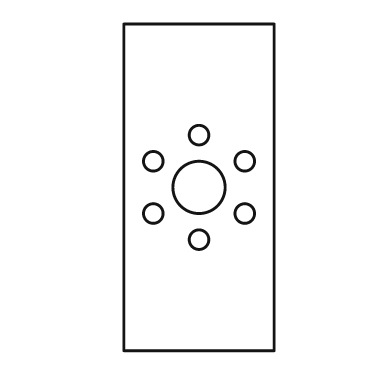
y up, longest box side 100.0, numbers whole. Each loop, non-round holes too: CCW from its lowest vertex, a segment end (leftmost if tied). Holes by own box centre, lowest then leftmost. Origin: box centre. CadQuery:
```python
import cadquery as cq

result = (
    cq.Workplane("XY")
    .moveTo(-23.0, -50.0)
    .lineTo(23.0, -50.0)
    .lineTo(23.0, 50.0)
    .lineTo(-23.0, 50.0)
    .close()
    .moveTo(0.0, -16.0)
    .circle(3.0)
    .moveTo(-14.0, -8.0)
    .circle(3.0)
    .moveTo(14.0, -8.0)
    .circle(3.0)
    .moveTo(0.0, 0.0)
    .circle(8.0)
    .moveTo(-14.0, 8.0)
    .circle(3.0)
    .moveTo(14.0, 8.0)
    .circle(3.0)
    .moveTo(0.0, 16.0)
    .circle(3.0)
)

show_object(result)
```